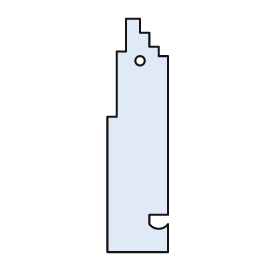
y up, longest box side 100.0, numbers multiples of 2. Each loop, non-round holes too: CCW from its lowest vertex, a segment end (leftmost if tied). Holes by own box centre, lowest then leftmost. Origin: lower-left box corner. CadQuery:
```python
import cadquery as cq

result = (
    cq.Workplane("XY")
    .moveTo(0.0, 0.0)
    .lineTo(26.0, 0.0)
    .lineTo(26.0, 12.0)
    .threePointArc((22.0, 10.0), (18.0, 12.0))
    .lineTo(18.0, 16.0)
    .lineTo(26.0, 16.0)
    .lineTo(26.0, 84.0)
    .lineTo(22.0, 84.0)
    .lineTo(22.0, 88.0)
    .lineTo(18.0, 88.0)
    .lineTo(18.0, 94.0)
    .lineTo(14.0, 94.0)
    .lineTo(14.0, 100.0)
    .lineTo(8.0, 100.0)
    .lineTo(8.0, 86.0)
    .lineTo(4.0, 86.0)
    .lineTo(4.0, 58.0)
    .lineTo(0.0, 58.0)
    .close()
    .moveTo(14.0, 82.0)
    .circle(2.0)
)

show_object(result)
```